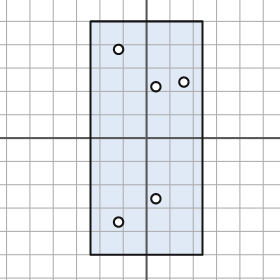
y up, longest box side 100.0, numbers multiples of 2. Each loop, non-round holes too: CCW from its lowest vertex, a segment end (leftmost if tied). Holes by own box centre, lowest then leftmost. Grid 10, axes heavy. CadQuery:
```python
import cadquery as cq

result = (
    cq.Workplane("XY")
    .moveTo(-24.0, -50.0)
    .lineTo(24.0, -50.0)
    .lineTo(24.0, 50.0)
    .lineTo(-24.0, 50.0)
    .close()
    .moveTo(-12.0, -36.0)
    .circle(2.0)
    .moveTo(4.0, -26.0)
    .circle(2.0)
    .moveTo(4.0, 22.0)
    .circle(2.0)
    .moveTo(16.0, 24.0)
    .circle(2.0)
    .moveTo(-12.0, 38.0)
    .circle(2.0)
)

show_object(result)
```